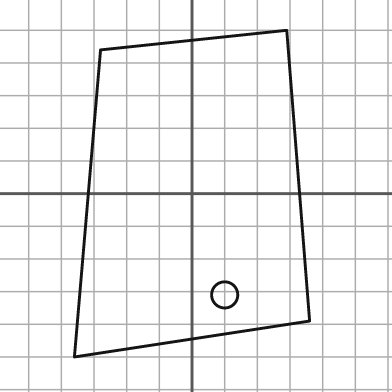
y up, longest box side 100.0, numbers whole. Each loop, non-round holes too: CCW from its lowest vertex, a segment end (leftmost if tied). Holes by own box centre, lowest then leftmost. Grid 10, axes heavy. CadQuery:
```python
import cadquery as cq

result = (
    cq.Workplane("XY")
    .moveTo(-36.0, -50.0)
    .lineTo(36.0, -39.0)
    .lineTo(29.0, 50.0)
    .lineTo(-28.0, 44.0)
    .close()
    .moveTo(10.0, -31.0)
    .circle(4.0)
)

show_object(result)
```